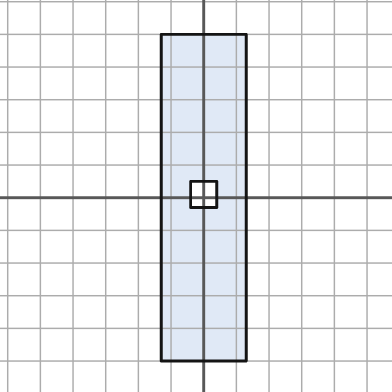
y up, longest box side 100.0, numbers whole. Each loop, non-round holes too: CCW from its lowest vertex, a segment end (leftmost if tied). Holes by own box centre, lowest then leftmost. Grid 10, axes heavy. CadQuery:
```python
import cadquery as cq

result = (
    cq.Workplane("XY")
    .moveTo(-13.0, -50.0)
    .lineTo(13.0, -50.0)
    .lineTo(13.0, 50.0)
    .lineTo(-13.0, 50.0)
    .close()
    .moveTo(-4.0, -3.0)
    .lineTo(4.0, -3.0)
    .lineTo(4.0, 5.0)
    .lineTo(-4.0, 5.0)
    .close()
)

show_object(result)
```